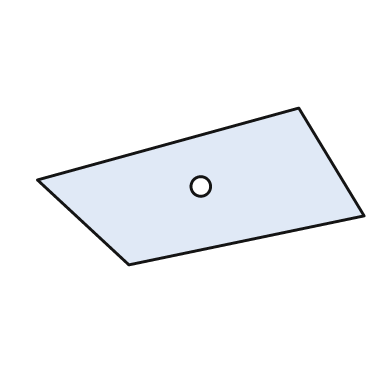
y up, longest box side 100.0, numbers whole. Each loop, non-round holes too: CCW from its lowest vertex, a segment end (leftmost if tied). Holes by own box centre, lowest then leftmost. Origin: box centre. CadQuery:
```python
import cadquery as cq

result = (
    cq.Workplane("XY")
    .moveTo(-22.0, -24.0)
    .lineTo(50.0, -9.0)
    .lineTo(30.0, 24.0)
    .lineTo(-50.0, 2.0)
    .close()
    .moveTo(0.0, 0.0)
    .circle(3.0)
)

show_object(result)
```